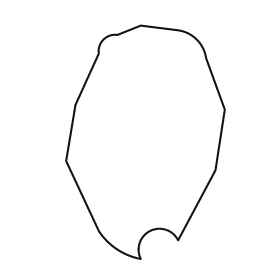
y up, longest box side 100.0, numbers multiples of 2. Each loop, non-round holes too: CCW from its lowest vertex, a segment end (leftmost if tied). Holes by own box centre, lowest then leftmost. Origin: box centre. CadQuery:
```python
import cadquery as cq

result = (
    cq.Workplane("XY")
    .moveTo(-2.0, -50.0)
    .threePointArc((2.0, -38.0), (14.0, -42.0))
    .lineTo(30.0, -12.0)
    .lineTo(34.0, 14.0)
    .lineTo(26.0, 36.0)
    .threePointArc((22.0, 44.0), (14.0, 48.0))
    .lineTo(-2.0, 50.0)
    .lineTo(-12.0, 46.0)
    .threePointArc((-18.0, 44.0), (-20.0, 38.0))
    .lineTo(-30.0, 16.0)
    .lineTo(-34.0, -8.0)
    .lineTo(-20.0, -38.0)
    .threePointArc((-12.0, -46.0), (-2.0, -50.0))
    .close()
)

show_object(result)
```